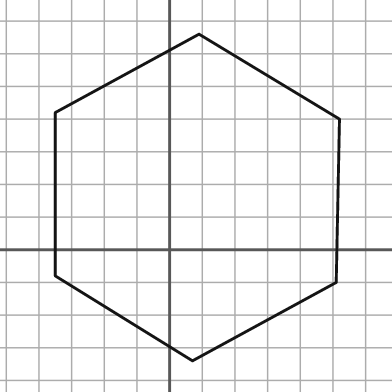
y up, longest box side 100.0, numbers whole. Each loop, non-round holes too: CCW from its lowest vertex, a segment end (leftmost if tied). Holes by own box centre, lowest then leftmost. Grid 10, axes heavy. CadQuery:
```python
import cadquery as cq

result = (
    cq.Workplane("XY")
    .moveTo(7.0, -34.0)
    .lineTo(51.0, -10.0)
    .lineTo(52.0, 40.0)
    .lineTo(9.0, 66.0)
    .lineTo(-35.0, 42.0)
    .lineTo(-35.0, -8.0)
    .close()
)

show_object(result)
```